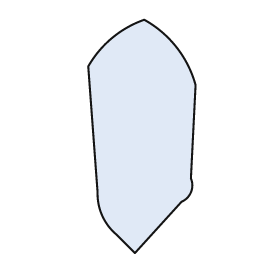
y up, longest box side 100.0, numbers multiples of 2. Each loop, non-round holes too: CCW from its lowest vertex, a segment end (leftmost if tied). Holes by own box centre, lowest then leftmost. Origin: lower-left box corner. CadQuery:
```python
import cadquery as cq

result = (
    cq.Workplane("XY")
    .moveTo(20.0, 0.0)
    .lineTo(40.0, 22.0)
    .threePointArc((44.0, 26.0), (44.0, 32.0))
    .lineTo(46.0, 72.0)
    .threePointArc((38.0, 88.0), (24.0, 100.0))
    .threePointArc((10.0, 92.0), (0.0, 80.0))
    .lineTo(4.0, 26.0)
    .threePointArc((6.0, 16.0), (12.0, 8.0))
    .close()
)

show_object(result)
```